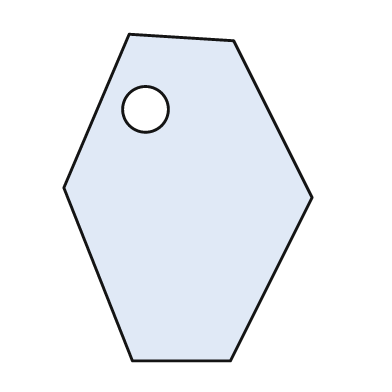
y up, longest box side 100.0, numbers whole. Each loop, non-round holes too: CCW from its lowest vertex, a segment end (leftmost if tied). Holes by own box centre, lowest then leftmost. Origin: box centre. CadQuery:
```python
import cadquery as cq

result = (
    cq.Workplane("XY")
    .moveTo(-17.0, -50.0)
    .lineTo(13.0, -50.0)
    .lineTo(38.0, 0.0)
    .lineTo(14.0, 48.0)
    .lineTo(-18.0, 50.0)
    .lineTo(-38.0, 3.0)
    .close()
    .moveTo(-13.0, 27.0)
    .circle(7.0)
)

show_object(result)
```